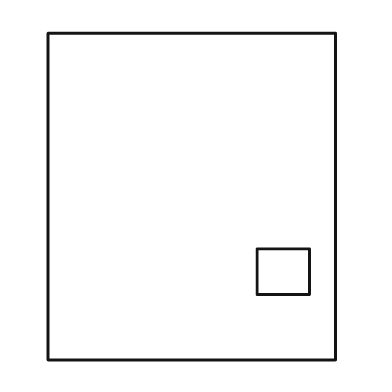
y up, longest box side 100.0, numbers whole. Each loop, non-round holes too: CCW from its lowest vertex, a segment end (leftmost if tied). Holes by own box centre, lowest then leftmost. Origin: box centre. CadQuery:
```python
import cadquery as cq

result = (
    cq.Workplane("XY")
    .moveTo(-44.0, -50.0)
    .lineTo(44.0, -50.0)
    .lineTo(44.0, 50.0)
    .lineTo(-44.0, 50.0)
    .close()
    .moveTo(20.0, -30.0)
    .lineTo(36.0, -30.0)
    .lineTo(36.0, -16.0)
    .lineTo(20.0, -16.0)
    .close()
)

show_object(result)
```